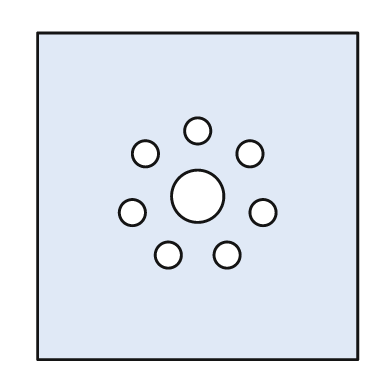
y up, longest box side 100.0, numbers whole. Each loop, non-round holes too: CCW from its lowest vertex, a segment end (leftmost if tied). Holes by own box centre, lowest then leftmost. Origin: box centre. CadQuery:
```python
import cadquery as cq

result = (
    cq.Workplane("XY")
    .moveTo(-49.0, -50.0)
    .lineTo(49.0, -50.0)
    .lineTo(49.0, 50.0)
    .lineTo(-49.0, 50.0)
    .close()
    .moveTo(-9.0, -18.0)
    .circle(4.0)
    .moveTo(9.0, -18.0)
    .circle(4.0)
    .moveTo(-20.0, -5.0)
    .circle(4.0)
    .moveTo(20.0, -5.0)
    .circle(4.0)
    .moveTo(0.0, 0.0)
    .circle(8.0)
    .moveTo(-16.0, 13.0)
    .circle(4.0)
    .moveTo(16.0, 13.0)
    .circle(4.0)
    .moveTo(0.0, 20.0)
    .circle(4.0)
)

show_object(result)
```